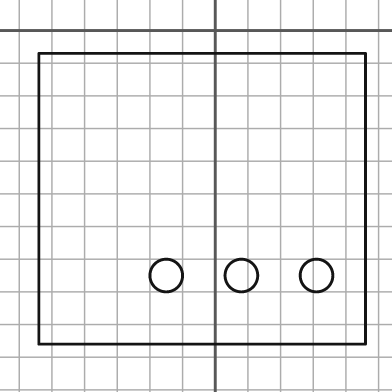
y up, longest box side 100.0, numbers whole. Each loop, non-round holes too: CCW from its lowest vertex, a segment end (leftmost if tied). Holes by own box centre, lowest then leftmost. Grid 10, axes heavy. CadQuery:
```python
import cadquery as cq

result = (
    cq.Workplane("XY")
    .moveTo(-54.0, -96.0)
    .lineTo(46.0, -96.0)
    .lineTo(46.0, -7.0)
    .lineTo(-54.0, -7.0)
    .close()
    .moveTo(-15.0, -75.0)
    .circle(5.0)
    .moveTo(8.0, -75.0)
    .circle(5.0)
    .moveTo(31.0, -75.0)
    .circle(5.0)
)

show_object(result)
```